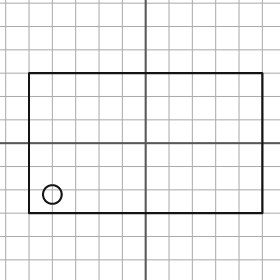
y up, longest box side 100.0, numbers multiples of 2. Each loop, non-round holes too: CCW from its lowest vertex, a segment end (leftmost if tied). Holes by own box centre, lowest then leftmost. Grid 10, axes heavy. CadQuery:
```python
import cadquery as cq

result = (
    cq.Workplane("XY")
    .moveTo(-50.0, -30.0)
    .lineTo(50.0, -30.0)
    .lineTo(50.0, 30.0)
    .lineTo(-50.0, 30.0)
    .close()
    .moveTo(-40.0, -22.0)
    .circle(4.0)
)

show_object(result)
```